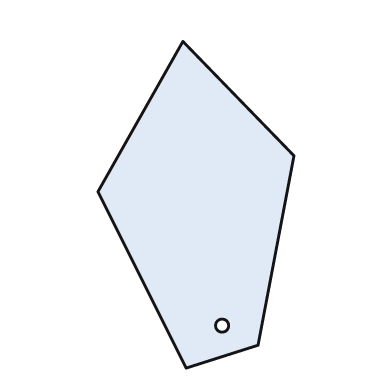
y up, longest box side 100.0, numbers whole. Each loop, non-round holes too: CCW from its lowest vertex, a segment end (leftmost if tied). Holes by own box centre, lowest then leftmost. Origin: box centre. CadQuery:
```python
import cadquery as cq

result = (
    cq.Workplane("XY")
    .moveTo(-3.0, -50.0)
    .lineTo(19.0, -43.0)
    .lineTo(30.0, 15.0)
    .lineTo(-4.0, 50.0)
    .lineTo(-30.0, 4.0)
    .close()
    .moveTo(8.0, -37.0)
    .circle(2.0)
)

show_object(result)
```